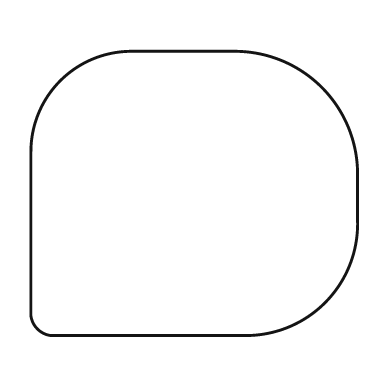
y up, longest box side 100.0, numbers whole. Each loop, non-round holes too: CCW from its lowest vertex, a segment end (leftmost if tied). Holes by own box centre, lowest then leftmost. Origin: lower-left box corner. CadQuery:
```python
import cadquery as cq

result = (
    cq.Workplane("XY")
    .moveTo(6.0, 0.0)
    .lineTo(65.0, 0.0)
    .threePointArc((90.0, 10.0), (100.0, 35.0))
    .lineTo(100.0, 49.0)
    .threePointArc((89.0, 76.0), (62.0, 87.0))
    .lineTo(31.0, 87.0)
    .threePointArc((9.0, 78.0), (0.0, 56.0))
    .lineTo(0.0, 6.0)
    .threePointArc((2.0, 2.0), (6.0, 0.0))
    .close()
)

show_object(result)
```